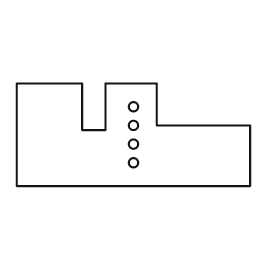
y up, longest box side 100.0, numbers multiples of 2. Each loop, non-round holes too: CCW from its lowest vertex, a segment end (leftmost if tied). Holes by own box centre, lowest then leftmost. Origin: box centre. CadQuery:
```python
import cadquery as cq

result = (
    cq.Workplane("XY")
    .moveTo(-50.0, -22.0)
    .lineTo(50.0, -22.0)
    .lineTo(50.0, 4.0)
    .lineTo(10.0, 4.0)
    .lineTo(10.0, 22.0)
    .lineTo(-12.0, 22.0)
    .lineTo(-12.0, 2.0)
    .lineTo(-22.0, 2.0)
    .lineTo(-22.0, 22.0)
    .lineTo(-50.0, 22.0)
    .close()
    .moveTo(0.0, -12.0)
    .circle(2.0)
    .moveTo(0.0, -4.0)
    .circle(2.0)
    .moveTo(0.0, 4.0)
    .circle(2.0)
    .moveTo(0.0, 12.0)
    .circle(2.0)
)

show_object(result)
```